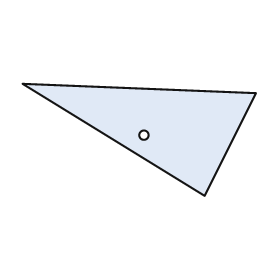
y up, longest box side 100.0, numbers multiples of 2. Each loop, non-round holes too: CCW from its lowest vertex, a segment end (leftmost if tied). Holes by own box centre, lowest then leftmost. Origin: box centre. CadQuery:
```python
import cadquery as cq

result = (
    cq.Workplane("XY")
    .moveTo(28.0, -24.0)
    .lineTo(50.0, 20.0)
    .lineTo(-50.0, 24.0)
    .close()
    .moveTo(2.0, 2.0)
    .circle(2.0)
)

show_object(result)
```